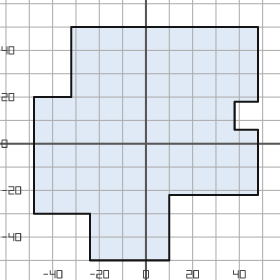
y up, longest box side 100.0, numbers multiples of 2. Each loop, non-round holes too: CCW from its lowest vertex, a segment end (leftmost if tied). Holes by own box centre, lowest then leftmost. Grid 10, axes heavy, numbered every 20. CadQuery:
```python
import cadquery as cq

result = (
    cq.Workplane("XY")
    .moveTo(-24.0, -50.0)
    .lineTo(10.0, -50.0)
    .lineTo(10.0, -22.0)
    .lineTo(48.0, -22.0)
    .lineTo(48.0, 6.0)
    .lineTo(38.0, 6.0)
    .lineTo(38.0, 18.0)
    .lineTo(48.0, 18.0)
    .lineTo(48.0, 50.0)
    .lineTo(-32.0, 50.0)
    .lineTo(-32.0, 20.0)
    .lineTo(-48.0, 20.0)
    .lineTo(-48.0, -30.0)
    .lineTo(-24.0, -30.0)
    .close()
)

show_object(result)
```